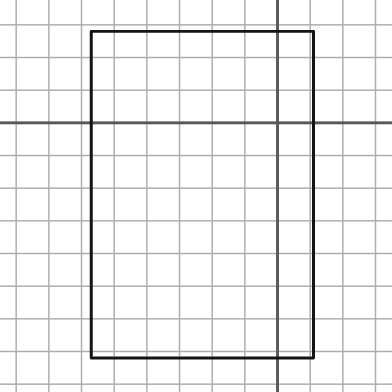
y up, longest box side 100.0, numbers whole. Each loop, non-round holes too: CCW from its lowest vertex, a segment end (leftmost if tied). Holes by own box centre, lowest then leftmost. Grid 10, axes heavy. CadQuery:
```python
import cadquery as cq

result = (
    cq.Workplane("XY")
    .moveTo(-57.0, -72.0)
    .lineTo(11.0, -72.0)
    .lineTo(11.0, 28.0)
    .lineTo(-57.0, 28.0)
    .close()
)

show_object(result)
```